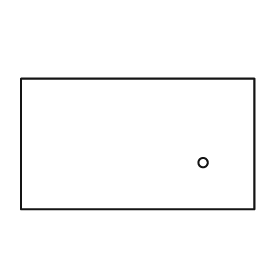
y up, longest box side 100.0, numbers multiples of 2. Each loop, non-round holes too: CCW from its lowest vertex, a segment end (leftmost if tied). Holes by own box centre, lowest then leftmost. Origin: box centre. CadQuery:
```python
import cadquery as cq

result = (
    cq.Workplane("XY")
    .moveTo(-50.0, -28.0)
    .lineTo(50.0, -28.0)
    .lineTo(50.0, 28.0)
    .lineTo(-50.0, 28.0)
    .close()
    .moveTo(28.0, -8.0)
    .circle(2.0)
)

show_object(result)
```